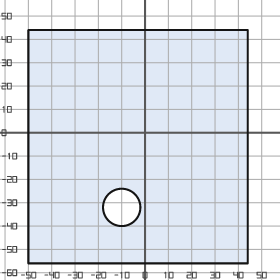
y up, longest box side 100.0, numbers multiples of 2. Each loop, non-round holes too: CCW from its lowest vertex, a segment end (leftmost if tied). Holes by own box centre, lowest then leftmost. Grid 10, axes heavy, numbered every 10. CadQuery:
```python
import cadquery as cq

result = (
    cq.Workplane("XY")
    .moveTo(-50.0, -56.0)
    .lineTo(44.0, -56.0)
    .lineTo(44.0, 44.0)
    .lineTo(-50.0, 44.0)
    .close()
    .moveTo(-10.0, -32.0)
    .circle(8.0)
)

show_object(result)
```